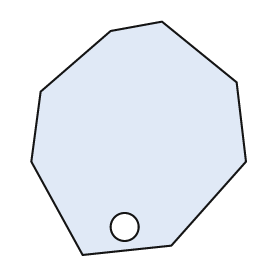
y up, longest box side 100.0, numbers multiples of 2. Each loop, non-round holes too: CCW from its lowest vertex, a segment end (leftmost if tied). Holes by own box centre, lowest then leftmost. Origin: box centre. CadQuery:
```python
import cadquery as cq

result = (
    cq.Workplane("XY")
    .moveTo(-24.0, -50.0)
    .lineTo(14.0, -46.0)
    .lineTo(46.0, -10.0)
    .lineTo(42.0, 24.0)
    .lineTo(10.0, 50.0)
    .lineTo(-12.0, 46.0)
    .lineTo(-42.0, 20.0)
    .lineTo(-46.0, -10.0)
    .close()
    .moveTo(-6.0, -38.0)
    .circle(6.0)
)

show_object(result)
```